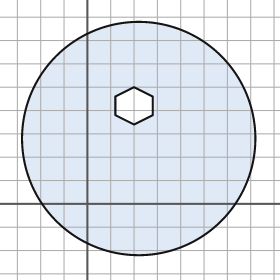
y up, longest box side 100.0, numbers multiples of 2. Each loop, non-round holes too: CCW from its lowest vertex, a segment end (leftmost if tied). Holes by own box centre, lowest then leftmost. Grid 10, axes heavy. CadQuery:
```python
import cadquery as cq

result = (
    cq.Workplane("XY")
    .moveTo(22.0, 28.0)
    .circle(50.0)
    .moveTo(20.0, 34.0)
    .lineTo(28.0, 38.0)
    .lineTo(28.0, 46.0)
    .lineTo(20.0, 50.0)
    .lineTo(12.0, 46.0)
    .lineTo(12.0, 38.0)
    .close()
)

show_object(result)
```